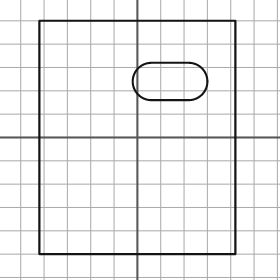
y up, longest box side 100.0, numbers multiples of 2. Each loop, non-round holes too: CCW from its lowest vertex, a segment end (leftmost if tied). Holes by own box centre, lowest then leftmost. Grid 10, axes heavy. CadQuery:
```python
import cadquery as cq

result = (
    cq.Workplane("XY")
    .moveTo(-42.0, -50.0)
    .lineTo(42.0, -50.0)
    .lineTo(42.0, 50.0)
    .lineTo(-42.0, 50.0)
    .close()
    .moveTo(6.0, 16.0)
    .lineTo(22.0, 16.0)
    .threePointArc((30.0, 24.0), (22.0, 32.0))
    .lineTo(6.0, 32.0)
    .threePointArc((-2.0, 24.0), (6.0, 16.0))
    .close()
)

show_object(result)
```